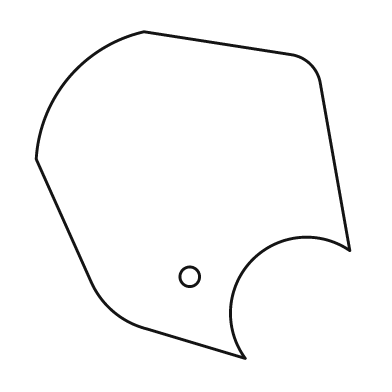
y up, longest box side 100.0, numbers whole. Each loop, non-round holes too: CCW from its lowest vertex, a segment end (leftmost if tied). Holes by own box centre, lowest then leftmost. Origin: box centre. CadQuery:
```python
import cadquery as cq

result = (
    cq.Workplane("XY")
    .moveTo(16.0, -50.0)
    .threePointArc((18.0, -20.0), (48.0, -17.0))
    .lineTo(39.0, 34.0)
    .threePointArc((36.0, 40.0), (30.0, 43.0))
    .lineTo(-15.0, 50.0)
    .threePointArc((-38.0, 36.0), (-48.0, 11.0))
    .lineTo(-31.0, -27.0)
    .threePointArc((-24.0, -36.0), (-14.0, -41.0))
    .close()
    .moveTo(-1.0, -25.0)
    .circle(3.0)
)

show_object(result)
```